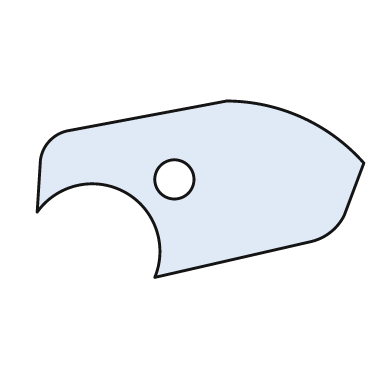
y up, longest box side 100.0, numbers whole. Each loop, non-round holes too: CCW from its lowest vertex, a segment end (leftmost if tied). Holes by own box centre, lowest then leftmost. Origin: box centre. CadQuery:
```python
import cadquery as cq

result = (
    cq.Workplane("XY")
    .moveTo(-14.0, -27.0)
    .lineTo(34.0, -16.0)
    .threePointArc((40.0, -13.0), (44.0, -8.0))
    .lineTo(50.0, 8.0)
    .threePointArc((31.0, 22.0), (8.0, 27.0))
    .lineTo(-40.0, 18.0)
    .threePointArc((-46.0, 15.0), (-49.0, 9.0))
    .lineTo(-50.0, -7.0)
    .threePointArc((-23.0, -1.0), (-14.0, -27.0))
    .close()
    .moveTo(-8.0, 3.0)
    .circle(6.0)
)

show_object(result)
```